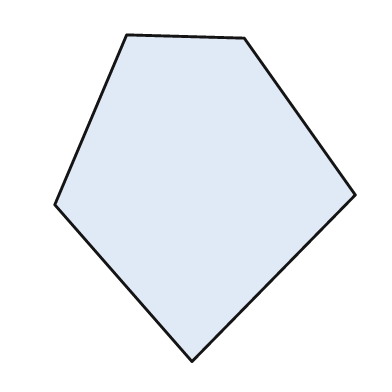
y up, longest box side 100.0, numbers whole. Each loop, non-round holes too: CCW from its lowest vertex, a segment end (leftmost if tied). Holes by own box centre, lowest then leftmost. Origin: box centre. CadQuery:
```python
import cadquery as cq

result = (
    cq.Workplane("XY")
    .moveTo(-4.0, -50.0)
    .lineTo(46.0, 1.0)
    .lineTo(12.0, 49.0)
    .lineTo(-24.0, 50.0)
    .lineTo(-46.0, -2.0)
    .close()
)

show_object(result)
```